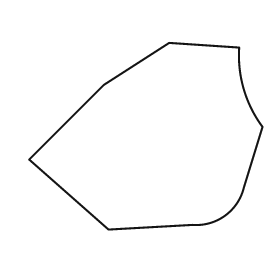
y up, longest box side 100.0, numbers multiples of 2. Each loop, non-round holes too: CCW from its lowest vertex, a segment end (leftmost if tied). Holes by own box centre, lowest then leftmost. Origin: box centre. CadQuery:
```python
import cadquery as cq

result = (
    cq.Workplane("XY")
    .moveTo(-16.0, -40.0)
    .lineTo(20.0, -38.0)
    .threePointArc((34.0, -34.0), (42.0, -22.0))
    .lineTo(50.0, 4.0)
    .threePointArc((42.0, 20.0), (40.0, 38.0))
    .lineTo(10.0, 40.0)
    .lineTo(-18.0, 22.0)
    .lineTo(-50.0, -10.0)
    .close()
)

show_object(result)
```